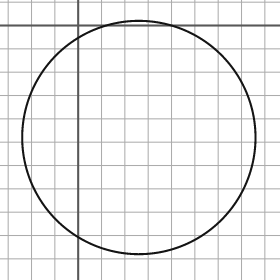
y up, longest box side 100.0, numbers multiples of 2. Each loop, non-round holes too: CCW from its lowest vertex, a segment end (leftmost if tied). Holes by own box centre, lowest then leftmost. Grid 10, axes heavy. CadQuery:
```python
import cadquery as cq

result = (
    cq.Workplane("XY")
    .moveTo(26.0, -48.0)
    .circle(50.0)
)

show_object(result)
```